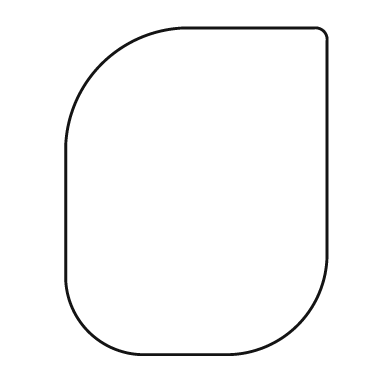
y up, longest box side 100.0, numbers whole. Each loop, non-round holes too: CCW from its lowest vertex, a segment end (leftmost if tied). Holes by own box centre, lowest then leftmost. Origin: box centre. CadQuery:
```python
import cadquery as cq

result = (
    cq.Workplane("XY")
    .moveTo(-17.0, -50.0)
    .lineTo(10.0, -50.0)
    .threePointArc((31.0, -41.0), (40.0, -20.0))
    .lineTo(40.0, 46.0)
    .threePointArc((39.0, 49.0), (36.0, 50.0))
    .lineTo(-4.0, 50.0)
    .threePointArc((-29.0, 39.0), (-40.0, 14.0))
    .lineTo(-40.0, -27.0)
    .threePointArc((-33.0, -43.0), (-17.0, -50.0))
    .close()
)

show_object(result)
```